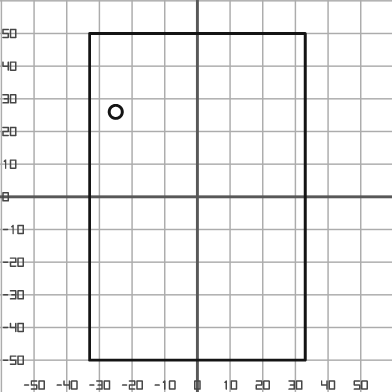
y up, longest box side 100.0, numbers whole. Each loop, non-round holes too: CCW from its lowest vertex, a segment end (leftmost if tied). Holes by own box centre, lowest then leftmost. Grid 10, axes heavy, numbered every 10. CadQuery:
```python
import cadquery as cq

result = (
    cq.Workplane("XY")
    .moveTo(-33.0, -50.0)
    .lineTo(33.0, -50.0)
    .lineTo(33.0, 50.0)
    .lineTo(-33.0, 50.0)
    .close()
    .moveTo(-25.0, 26.0)
    .circle(2.0)
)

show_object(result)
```